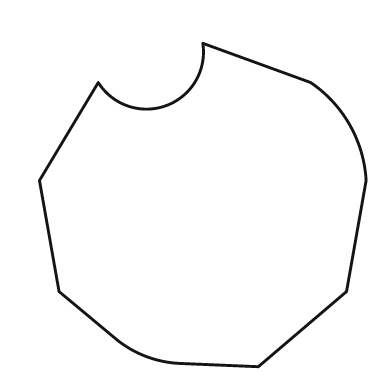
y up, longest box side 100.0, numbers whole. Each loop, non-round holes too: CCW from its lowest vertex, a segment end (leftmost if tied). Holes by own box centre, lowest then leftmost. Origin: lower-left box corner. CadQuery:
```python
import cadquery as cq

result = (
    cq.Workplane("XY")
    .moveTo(67.0, 0.0)
    .lineTo(94.0, 23.0)
    .lineTo(100.0, 57.0)
    .threePointArc((95.0, 74.0), (83.0, 87.0))
    .lineTo(50.0, 99.0)
    .threePointArc((39.0, 80.0), (18.0, 87.0))
    .lineTo(0.0, 57.0)
    .lineTo(6.0, 23.0)
    .lineTo(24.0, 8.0)
    .threePointArc((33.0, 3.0), (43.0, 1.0))
    .close()
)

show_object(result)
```